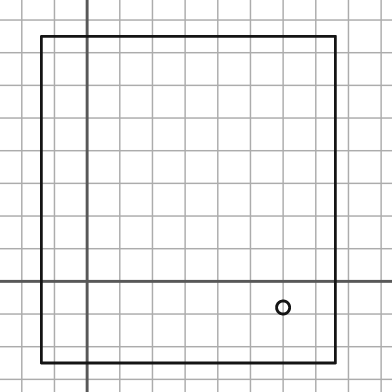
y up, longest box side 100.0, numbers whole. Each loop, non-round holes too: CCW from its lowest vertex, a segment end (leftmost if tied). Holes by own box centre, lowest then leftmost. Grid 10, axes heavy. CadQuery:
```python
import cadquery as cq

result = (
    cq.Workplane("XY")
    .moveTo(-14.0, -25.0)
    .lineTo(76.0, -25.0)
    .lineTo(76.0, 75.0)
    .lineTo(-14.0, 75.0)
    .close()
    .moveTo(60.0, -8.0)
    .circle(2.0)
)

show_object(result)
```